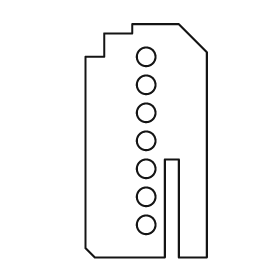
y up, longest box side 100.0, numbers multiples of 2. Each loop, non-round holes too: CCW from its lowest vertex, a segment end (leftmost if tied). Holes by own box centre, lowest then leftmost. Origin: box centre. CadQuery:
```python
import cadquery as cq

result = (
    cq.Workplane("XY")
    .moveTo(-22.0, -50.0)
    .lineTo(8.0, -50.0)
    .lineTo(8.0, -8.0)
    .lineTo(14.0, -8.0)
    .lineTo(14.0, -50.0)
    .lineTo(26.0, -50.0)
    .lineTo(26.0, 38.0)
    .lineTo(14.0, 50.0)
    .lineTo(-6.0, 50.0)
    .lineTo(-6.0, 46.0)
    .lineTo(-18.0, 46.0)
    .lineTo(-18.0, 36.0)
    .lineTo(-26.0, 36.0)
    .lineTo(-26.0, -46.0)
    .close()
    .moveTo(0.0, -36.0)
    .circle(4.0)
    .moveTo(0.0, -24.0)
    .circle(4.0)
    .moveTo(0.0, -12.0)
    .circle(4.0)
    .moveTo(0.0, 0.0)
    .circle(4.0)
    .moveTo(0.0, 12.0)
    .circle(4.0)
    .moveTo(0.0, 24.0)
    .circle(4.0)
    .moveTo(0.0, 36.0)
    .circle(4.0)
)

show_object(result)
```